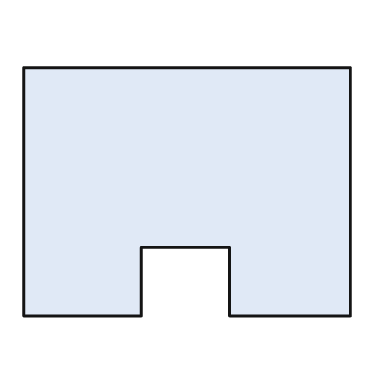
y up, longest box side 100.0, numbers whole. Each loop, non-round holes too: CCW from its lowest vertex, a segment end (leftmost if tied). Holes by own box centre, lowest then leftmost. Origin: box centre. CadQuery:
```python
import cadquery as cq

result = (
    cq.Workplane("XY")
    .moveTo(-50.0, -38.0)
    .lineTo(-14.0, -38.0)
    .lineTo(-14.0, -17.0)
    .lineTo(13.0, -17.0)
    .lineTo(13.0, -38.0)
    .lineTo(50.0, -38.0)
    .lineTo(50.0, 38.0)
    .lineTo(-50.0, 38.0)
    .close()
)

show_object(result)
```